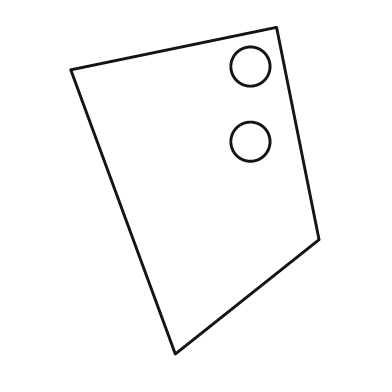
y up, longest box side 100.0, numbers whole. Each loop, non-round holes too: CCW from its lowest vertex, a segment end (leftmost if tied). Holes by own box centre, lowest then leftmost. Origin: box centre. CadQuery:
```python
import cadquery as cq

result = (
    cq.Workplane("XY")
    .moveTo(-6.0, -50.0)
    .lineTo(38.0, -15.0)
    .lineTo(25.0, 50.0)
    .lineTo(-38.0, 37.0)
    .close()
    .moveTo(17.0, 15.0)
    .circle(6.0)
    .moveTo(17.0, 38.0)
    .circle(6.0)
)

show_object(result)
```